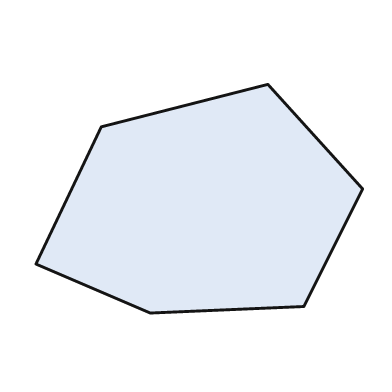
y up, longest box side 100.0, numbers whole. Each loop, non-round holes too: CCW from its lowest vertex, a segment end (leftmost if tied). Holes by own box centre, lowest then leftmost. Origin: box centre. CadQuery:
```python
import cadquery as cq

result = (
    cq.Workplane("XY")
    .moveTo(-15.0, -35.0)
    .lineTo(32.0, -33.0)
    .lineTo(50.0, 3.0)
    .lineTo(21.0, 35.0)
    .lineTo(-30.0, 22.0)
    .lineTo(-50.0, -20.0)
    .close()
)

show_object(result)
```